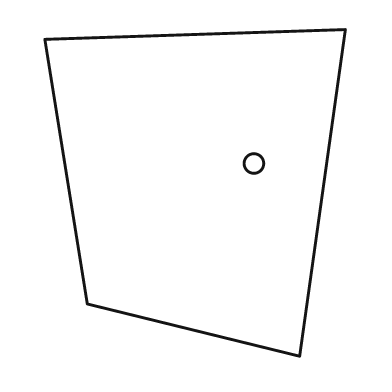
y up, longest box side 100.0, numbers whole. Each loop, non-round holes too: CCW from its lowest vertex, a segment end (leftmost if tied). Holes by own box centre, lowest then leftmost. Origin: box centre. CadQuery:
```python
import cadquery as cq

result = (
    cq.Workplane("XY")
    .moveTo(32.0, -50.0)
    .lineTo(46.0, 50.0)
    .lineTo(-46.0, 47.0)
    .lineTo(-33.0, -34.0)
    .close()
    .moveTo(18.0, 9.0)
    .circle(3.0)
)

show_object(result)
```